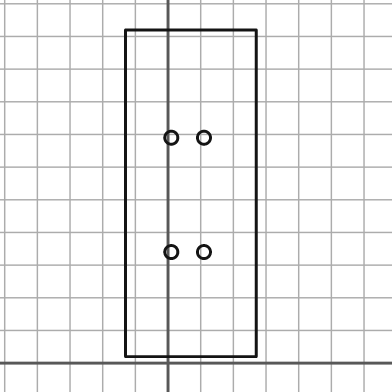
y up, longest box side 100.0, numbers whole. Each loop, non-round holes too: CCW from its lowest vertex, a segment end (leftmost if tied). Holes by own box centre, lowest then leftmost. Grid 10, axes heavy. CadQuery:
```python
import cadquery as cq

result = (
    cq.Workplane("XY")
    .moveTo(-13.0, 2.0)
    .lineTo(27.0, 2.0)
    .lineTo(27.0, 102.0)
    .lineTo(-13.0, 102.0)
    .close()
    .moveTo(1.0, 34.0)
    .circle(2.0)
    .moveTo(11.0, 34.0)
    .circle(2.0)
    .moveTo(1.0, 69.0)
    .circle(2.0)
    .moveTo(11.0, 69.0)
    .circle(2.0)
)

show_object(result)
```